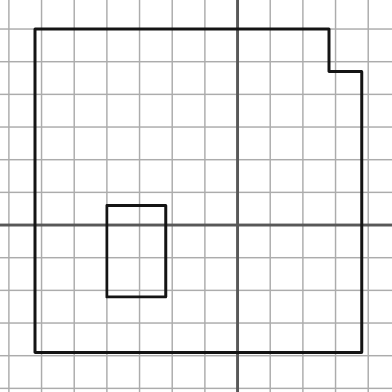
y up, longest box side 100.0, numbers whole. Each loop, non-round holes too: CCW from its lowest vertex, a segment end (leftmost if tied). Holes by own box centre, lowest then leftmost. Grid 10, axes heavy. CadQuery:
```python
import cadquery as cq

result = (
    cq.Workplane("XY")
    .moveTo(-62.0, -39.0)
    .lineTo(38.0, -39.0)
    .lineTo(38.0, 47.0)
    .lineTo(28.0, 47.0)
    .lineTo(28.0, 60.0)
    .lineTo(-62.0, 60.0)
    .close()
    .moveTo(-40.0, -22.0)
    .lineTo(-22.0, -22.0)
    .lineTo(-22.0, 6.0)
    .lineTo(-40.0, 6.0)
    .close()
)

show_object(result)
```